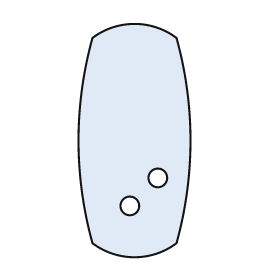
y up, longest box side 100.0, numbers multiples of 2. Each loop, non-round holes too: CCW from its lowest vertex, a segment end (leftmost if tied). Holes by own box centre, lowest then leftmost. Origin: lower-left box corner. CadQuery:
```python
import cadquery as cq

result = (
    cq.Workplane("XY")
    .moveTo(6.0, 6.0)
    .threePointArc((24.0, 0.0), (42.0, 6.0))
    .threePointArc((48.0, 50.0), (42.0, 94.0))
    .threePointArc((24.0, 100.0), (6.0, 94.0))
    .threePointArc((0.0, 50.0), (6.0, 6.0))
    .close()
    .moveTo(22.0, 22.0)
    .circle(4.0)
    .moveTo(34.0, 34.0)
    .circle(4.0)
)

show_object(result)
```